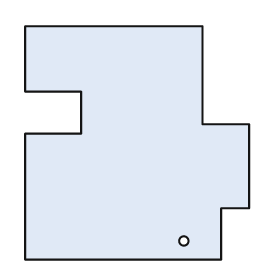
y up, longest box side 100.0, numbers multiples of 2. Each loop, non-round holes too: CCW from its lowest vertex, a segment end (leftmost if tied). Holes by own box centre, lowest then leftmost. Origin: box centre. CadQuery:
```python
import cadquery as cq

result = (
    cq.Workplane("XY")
    .moveTo(-48.0, -50.0)
    .lineTo(36.0, -50.0)
    .lineTo(36.0, -28.0)
    .lineTo(48.0, -28.0)
    .lineTo(48.0, 8.0)
    .lineTo(28.0, 8.0)
    .lineTo(28.0, 50.0)
    .lineTo(-48.0, 50.0)
    .lineTo(-48.0, 22.0)
    .lineTo(-24.0, 22.0)
    .lineTo(-24.0, 4.0)
    .lineTo(-48.0, 4.0)
    .close()
    .moveTo(20.0, -42.0)
    .circle(2.0)
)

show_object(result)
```